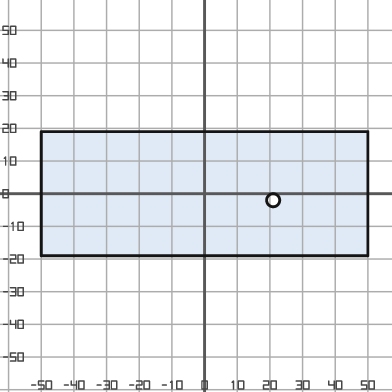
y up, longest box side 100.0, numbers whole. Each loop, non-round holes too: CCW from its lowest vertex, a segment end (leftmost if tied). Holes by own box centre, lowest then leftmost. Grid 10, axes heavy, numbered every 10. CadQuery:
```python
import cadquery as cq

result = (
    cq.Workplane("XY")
    .moveTo(-50.0, -19.0)
    .lineTo(50.0, -19.0)
    .lineTo(50.0, 19.0)
    .lineTo(-50.0, 19.0)
    .close()
    .moveTo(21.0, -2.0)
    .circle(2.0)
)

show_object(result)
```